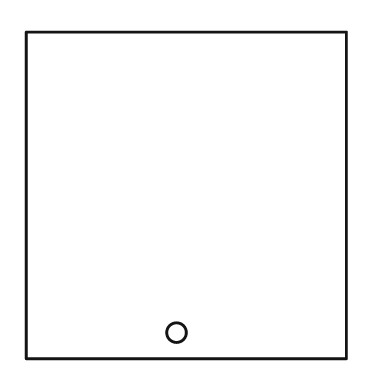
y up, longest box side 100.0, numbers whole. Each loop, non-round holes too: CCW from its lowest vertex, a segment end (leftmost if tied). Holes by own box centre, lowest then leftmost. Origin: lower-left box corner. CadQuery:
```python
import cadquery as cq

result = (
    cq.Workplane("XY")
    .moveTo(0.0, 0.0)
    .lineTo(98.0, 0.0)
    .lineTo(98.0, 100.0)
    .lineTo(0.0, 100.0)
    .close()
    .moveTo(46.0, 8.0)
    .circle(3.0)
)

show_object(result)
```